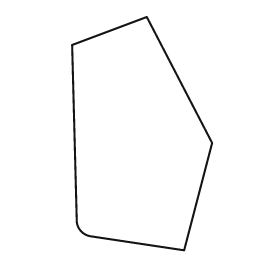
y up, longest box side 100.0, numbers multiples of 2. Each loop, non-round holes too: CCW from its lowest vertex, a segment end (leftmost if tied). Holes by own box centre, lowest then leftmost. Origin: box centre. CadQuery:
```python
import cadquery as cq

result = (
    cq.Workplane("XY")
    .moveTo(18.0, -50.0)
    .lineTo(30.0, -4.0)
    .lineTo(2.0, 50.0)
    .lineTo(-30.0, 38.0)
    .lineTo(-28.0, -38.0)
    .threePointArc((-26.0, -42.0), (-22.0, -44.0))
    .close()
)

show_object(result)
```